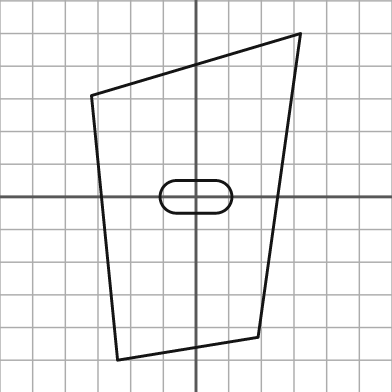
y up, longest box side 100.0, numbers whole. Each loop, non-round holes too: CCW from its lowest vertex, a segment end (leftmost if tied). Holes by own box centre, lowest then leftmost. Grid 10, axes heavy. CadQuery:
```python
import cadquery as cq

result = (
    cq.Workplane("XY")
    .moveTo(-24.0, -50.0)
    .lineTo(19.0, -43.0)
    .lineTo(32.0, 50.0)
    .lineTo(-32.0, 31.0)
    .close()
    .moveTo(-6.0, -5.0)
    .lineTo(6.0, -5.0)
    .threePointArc((11.0, 0.0), (6.0, 5.0))
    .lineTo(-6.0, 5.0)
    .threePointArc((-11.0, 0.0), (-6.0, -5.0))
    .close()
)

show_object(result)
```